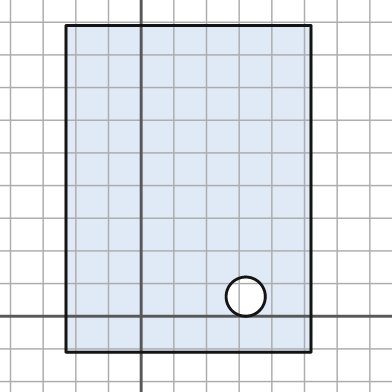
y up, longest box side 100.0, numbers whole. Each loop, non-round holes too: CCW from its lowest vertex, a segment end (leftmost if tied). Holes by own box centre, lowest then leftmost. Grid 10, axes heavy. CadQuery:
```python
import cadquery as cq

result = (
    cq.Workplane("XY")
    .moveTo(-23.0, -11.0)
    .lineTo(52.0, -11.0)
    .lineTo(52.0, 89.0)
    .lineTo(-23.0, 89.0)
    .close()
    .moveTo(32.0, 6.0)
    .circle(6.0)
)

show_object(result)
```